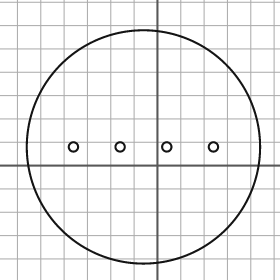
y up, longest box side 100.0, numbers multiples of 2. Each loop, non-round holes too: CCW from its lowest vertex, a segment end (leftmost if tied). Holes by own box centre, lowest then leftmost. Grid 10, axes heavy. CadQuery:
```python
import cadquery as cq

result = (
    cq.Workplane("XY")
    .moveTo(-6.0, 8.0)
    .circle(50.0)
    .moveTo(-36.0, 8.0)
    .circle(2.0)
    .moveTo(-16.0, 8.0)
    .circle(2.0)
    .moveTo(4.0, 8.0)
    .circle(2.0)
    .moveTo(24.0, 8.0)
    .circle(2.0)
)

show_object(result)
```